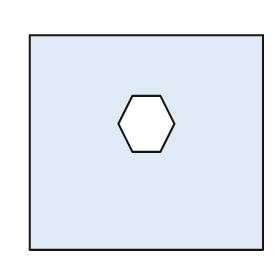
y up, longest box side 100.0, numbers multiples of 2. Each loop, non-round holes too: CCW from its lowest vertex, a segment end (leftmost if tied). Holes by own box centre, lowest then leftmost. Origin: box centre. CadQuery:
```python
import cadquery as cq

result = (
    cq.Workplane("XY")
    .moveTo(-50.0, -46.0)
    .lineTo(50.0, -46.0)
    .lineTo(50.0, 46.0)
    .lineTo(-50.0, 46.0)
    .close()
    .moveTo(-6.0, -4.0)
    .lineTo(6.0, -4.0)
    .lineTo(12.0, 8.0)
    .lineTo(6.0, 20.0)
    .lineTo(-6.0, 20.0)
    .lineTo(-12.0, 8.0)
    .close()
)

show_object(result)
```